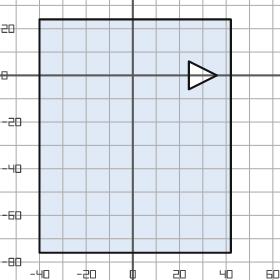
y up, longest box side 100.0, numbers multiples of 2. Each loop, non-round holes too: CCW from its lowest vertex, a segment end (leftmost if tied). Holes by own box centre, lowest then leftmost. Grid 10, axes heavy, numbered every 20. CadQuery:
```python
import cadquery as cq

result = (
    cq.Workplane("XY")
    .moveTo(-40.0, -76.0)
    .lineTo(42.0, -76.0)
    .lineTo(42.0, 24.0)
    .lineTo(-40.0, 24.0)
    .close()
    .moveTo(24.0, -6.0)
    .lineTo(36.0, 0.0)
    .lineTo(24.0, 6.0)
    .close()
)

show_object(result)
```